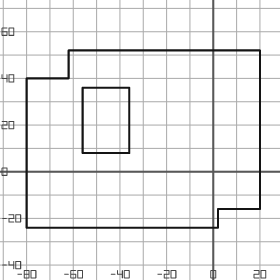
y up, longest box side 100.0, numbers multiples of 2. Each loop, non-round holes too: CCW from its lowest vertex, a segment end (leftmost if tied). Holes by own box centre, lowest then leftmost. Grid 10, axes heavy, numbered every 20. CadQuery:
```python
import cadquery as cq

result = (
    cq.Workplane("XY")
    .moveTo(-80.0, -24.0)
    .lineTo(2.0, -24.0)
    .lineTo(2.0, -16.0)
    .lineTo(20.0, -16.0)
    .lineTo(20.0, 52.0)
    .lineTo(-62.0, 52.0)
    .lineTo(-62.0, 40.0)
    .lineTo(-80.0, 40.0)
    .close()
    .moveTo(-56.0, 8.0)
    .lineTo(-36.0, 8.0)
    .lineTo(-36.0, 36.0)
    .lineTo(-56.0, 36.0)
    .close()
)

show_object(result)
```